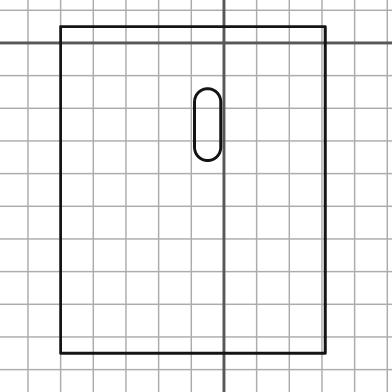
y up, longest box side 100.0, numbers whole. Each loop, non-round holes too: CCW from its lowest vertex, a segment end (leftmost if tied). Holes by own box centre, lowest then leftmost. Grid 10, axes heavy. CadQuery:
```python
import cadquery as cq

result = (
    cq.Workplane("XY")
    .moveTo(-50.0, -95.0)
    .lineTo(31.0, -95.0)
    .lineTo(31.0, 5.0)
    .lineTo(-50.0, 5.0)
    .close()
    .moveTo(-9.0, -32.0)
    .threePointArc((-5.0, -36.0), (-1.0, -32.0))
    .lineTo(-1.0, -18.0)
    .threePointArc((-5.0, -14.0), (-9.0, -18.0))
    .close()
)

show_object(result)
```